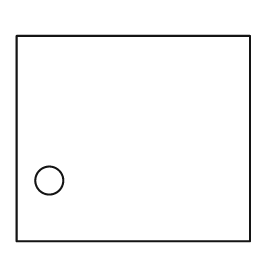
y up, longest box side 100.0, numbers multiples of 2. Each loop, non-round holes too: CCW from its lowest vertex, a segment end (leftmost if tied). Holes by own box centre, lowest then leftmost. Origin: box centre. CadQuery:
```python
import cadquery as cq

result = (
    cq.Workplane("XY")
    .moveTo(-50.0, -44.0)
    .lineTo(50.0, -44.0)
    .lineTo(50.0, 44.0)
    .lineTo(-50.0, 44.0)
    .close()
    .moveTo(-36.0, -18.0)
    .circle(6.0)
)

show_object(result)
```